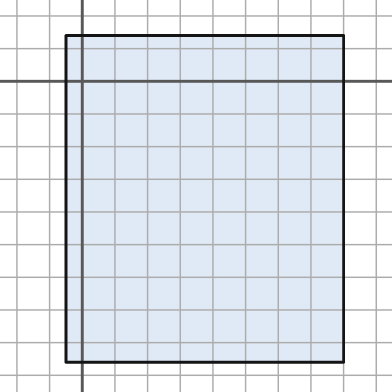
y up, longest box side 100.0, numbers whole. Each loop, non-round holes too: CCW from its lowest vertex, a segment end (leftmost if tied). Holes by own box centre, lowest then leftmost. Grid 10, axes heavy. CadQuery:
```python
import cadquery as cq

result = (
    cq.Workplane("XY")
    .moveTo(-5.0, -86.0)
    .lineTo(80.0, -86.0)
    .lineTo(80.0, 14.0)
    .lineTo(-5.0, 14.0)
    .close()
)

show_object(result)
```